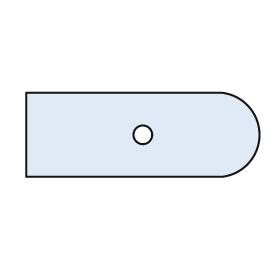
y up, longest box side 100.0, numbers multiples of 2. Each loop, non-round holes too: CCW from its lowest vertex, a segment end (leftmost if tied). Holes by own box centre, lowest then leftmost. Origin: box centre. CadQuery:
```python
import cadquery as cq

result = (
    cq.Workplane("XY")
    .moveTo(-50.0, -18.0)
    .lineTo(34.0, -18.0)
    .threePointArc((50.0, 0.0), (34.0, 18.0))
    .lineTo(-50.0, 18.0)
    .close()
    .moveTo(0.0, 0.0)
    .circle(4.0)
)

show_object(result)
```